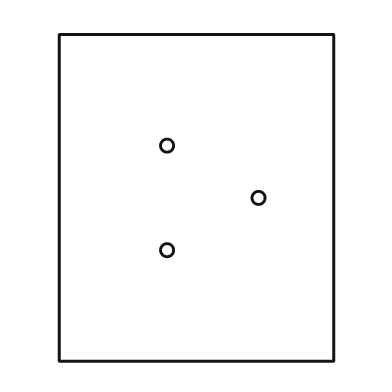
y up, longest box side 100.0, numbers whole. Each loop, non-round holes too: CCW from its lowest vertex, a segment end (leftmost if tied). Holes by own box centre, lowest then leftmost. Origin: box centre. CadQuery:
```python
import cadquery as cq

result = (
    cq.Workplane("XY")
    .moveTo(-42.0, -50.0)
    .lineTo(42.0, -50.0)
    .lineTo(42.0, 50.0)
    .lineTo(-42.0, 50.0)
    .close()
    .moveTo(-9.0, -16.0)
    .circle(2.0)
    .moveTo(19.0, 0.0)
    .circle(2.0)
    .moveTo(-9.0, 16.0)
    .circle(2.0)
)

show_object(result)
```